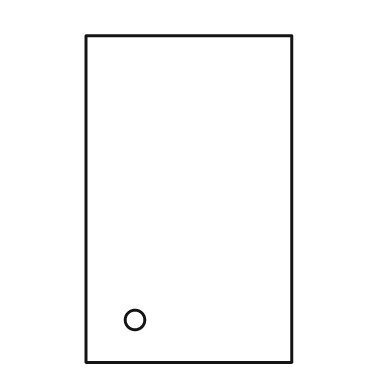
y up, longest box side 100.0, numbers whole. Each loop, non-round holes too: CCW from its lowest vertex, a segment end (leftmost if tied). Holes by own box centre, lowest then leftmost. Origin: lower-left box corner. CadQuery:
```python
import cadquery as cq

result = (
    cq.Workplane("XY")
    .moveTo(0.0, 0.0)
    .lineTo(63.0, 0.0)
    .lineTo(63.0, 100.0)
    .lineTo(0.0, 100.0)
    .close()
    .moveTo(15.0, 13.0)
    .circle(3.0)
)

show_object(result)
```